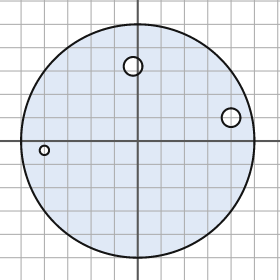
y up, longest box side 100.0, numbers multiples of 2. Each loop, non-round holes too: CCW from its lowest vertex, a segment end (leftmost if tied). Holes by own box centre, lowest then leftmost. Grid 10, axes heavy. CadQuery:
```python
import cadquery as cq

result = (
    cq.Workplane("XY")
    .moveTo(0.0, 0.0)
    .circle(50.0)
    .moveTo(-40.0, -4.0)
    .circle(2.0)
    .moveTo(40.0, 10.0)
    .circle(4.0)
    .moveTo(-2.0, 32.0)
    .circle(4.0)
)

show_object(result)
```